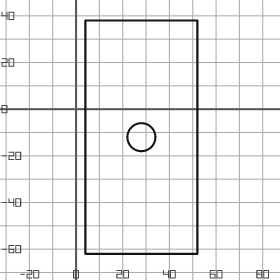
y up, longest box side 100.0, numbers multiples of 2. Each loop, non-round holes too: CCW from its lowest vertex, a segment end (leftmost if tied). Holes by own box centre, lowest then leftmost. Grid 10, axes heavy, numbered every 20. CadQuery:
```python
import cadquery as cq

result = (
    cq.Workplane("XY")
    .moveTo(4.0, -62.0)
    .lineTo(52.0, -62.0)
    .lineTo(52.0, 38.0)
    .lineTo(4.0, 38.0)
    .close()
    .moveTo(28.0, -12.0)
    .circle(6.0)
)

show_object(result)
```